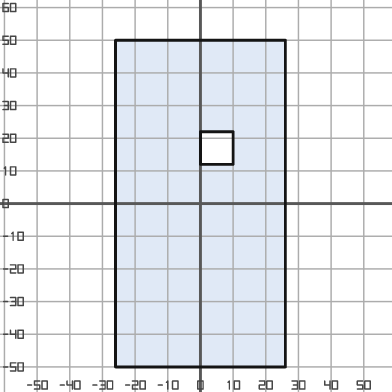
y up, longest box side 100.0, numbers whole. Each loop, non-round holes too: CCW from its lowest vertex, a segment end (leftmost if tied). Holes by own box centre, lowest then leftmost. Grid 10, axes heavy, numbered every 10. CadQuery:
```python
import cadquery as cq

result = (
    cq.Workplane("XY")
    .moveTo(-26.0, -50.0)
    .lineTo(26.0, -50.0)
    .lineTo(26.0, 50.0)
    .lineTo(-26.0, 50.0)
    .close()
    .moveTo(0.0, 12.0)
    .lineTo(10.0, 12.0)
    .lineTo(10.0, 22.0)
    .lineTo(0.0, 22.0)
    .close()
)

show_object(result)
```